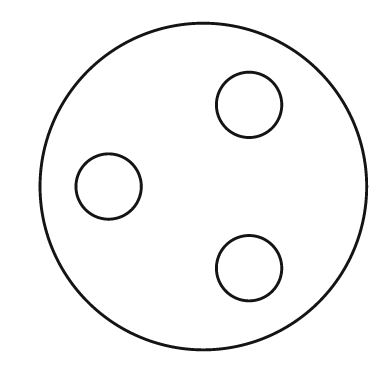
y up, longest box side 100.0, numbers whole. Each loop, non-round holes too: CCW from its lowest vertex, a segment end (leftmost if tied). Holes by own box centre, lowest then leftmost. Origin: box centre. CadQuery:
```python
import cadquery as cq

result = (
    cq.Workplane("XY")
    .moveTo(0.0, 0.0)
    .circle(50.0)
    .moveTo(14.0, -25.0)
    .circle(10.0)
    .moveTo(-29.0, 0.0)
    .circle(10.0)
    .moveTo(14.0, 25.0)
    .circle(10.0)
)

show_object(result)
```